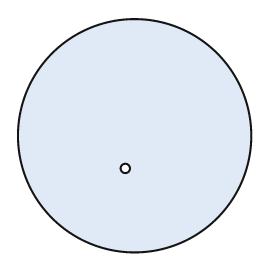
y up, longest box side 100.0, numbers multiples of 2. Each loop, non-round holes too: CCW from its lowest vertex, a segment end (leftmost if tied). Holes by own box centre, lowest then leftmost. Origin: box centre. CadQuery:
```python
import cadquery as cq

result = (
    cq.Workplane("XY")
    .moveTo(0.0, 0.0)
    .circle(50.0)
    .moveTo(-4.0, -14.0)
    .circle(2.0)
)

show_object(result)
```